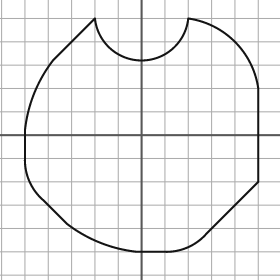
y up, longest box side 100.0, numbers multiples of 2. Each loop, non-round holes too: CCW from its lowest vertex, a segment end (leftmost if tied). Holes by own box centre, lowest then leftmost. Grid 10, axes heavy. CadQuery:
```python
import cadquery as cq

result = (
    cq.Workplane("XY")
    .moveTo(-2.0, -50.0)
    .lineTo(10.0, -50.0)
    .threePointArc((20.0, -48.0), (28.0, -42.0))
    .lineTo(50.0, -20.0)
    .lineTo(50.0, 20.0)
    .threePointArc((40.0, 40.0), (20.0, 50.0))
    .threePointArc((0.0, 32.0), (-20.0, 50.0))
    .lineTo(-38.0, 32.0)
    .threePointArc((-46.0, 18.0), (-50.0, 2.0))
    .lineTo(-50.0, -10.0)
    .threePointArc((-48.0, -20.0), (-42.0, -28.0))
    .lineTo(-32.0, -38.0)
    .threePointArc((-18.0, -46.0), (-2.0, -50.0))
    .close()
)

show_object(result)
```